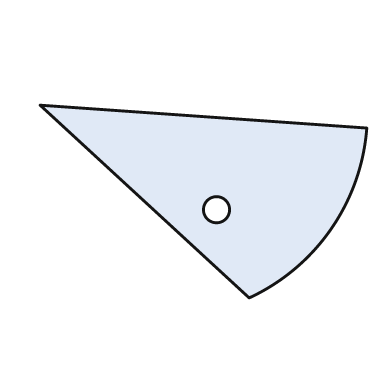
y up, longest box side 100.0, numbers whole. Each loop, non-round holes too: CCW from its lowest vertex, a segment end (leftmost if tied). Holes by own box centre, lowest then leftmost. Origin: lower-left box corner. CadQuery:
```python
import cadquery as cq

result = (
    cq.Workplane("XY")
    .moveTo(64.0, 0.0)
    .threePointArc((89.0, 21.0), (100.0, 52.0))
    .lineTo(0.0, 59.0)
    .close()
    .moveTo(54.0, 27.0)
    .circle(4.0)
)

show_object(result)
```